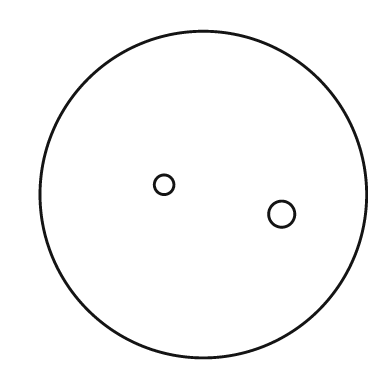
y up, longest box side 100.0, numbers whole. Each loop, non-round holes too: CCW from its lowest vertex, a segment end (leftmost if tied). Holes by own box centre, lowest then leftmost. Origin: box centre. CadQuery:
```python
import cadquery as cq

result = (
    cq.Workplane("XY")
    .moveTo(0.0, 0.0)
    .circle(50.0)
    .moveTo(24.0, -6.0)
    .circle(4.0)
    .moveTo(-12.0, 3.0)
    .circle(3.0)
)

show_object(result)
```